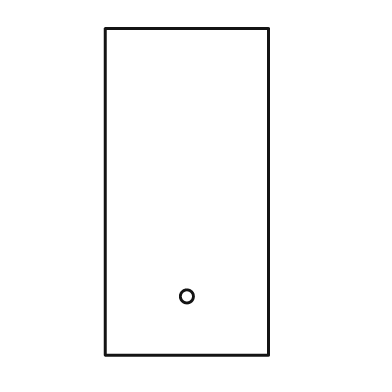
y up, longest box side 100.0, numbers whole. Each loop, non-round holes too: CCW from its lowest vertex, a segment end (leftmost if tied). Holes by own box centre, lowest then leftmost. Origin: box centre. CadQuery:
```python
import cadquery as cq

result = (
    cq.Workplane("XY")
    .moveTo(-25.0, -50.0)
    .lineTo(25.0, -50.0)
    .lineTo(25.0, 50.0)
    .lineTo(-25.0, 50.0)
    .close()
    .moveTo(0.0, -32.0)
    .circle(2.0)
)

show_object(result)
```